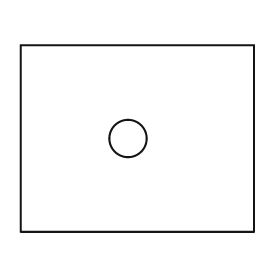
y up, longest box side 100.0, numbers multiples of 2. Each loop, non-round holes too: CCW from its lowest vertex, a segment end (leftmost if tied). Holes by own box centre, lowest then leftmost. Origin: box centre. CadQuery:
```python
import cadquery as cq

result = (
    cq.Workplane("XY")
    .moveTo(-50.0, -40.0)
    .lineTo(50.0, -40.0)
    .lineTo(50.0, 40.0)
    .lineTo(-50.0, 40.0)
    .close()
    .moveTo(-4.0, 0.0)
    .circle(8.0)
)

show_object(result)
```